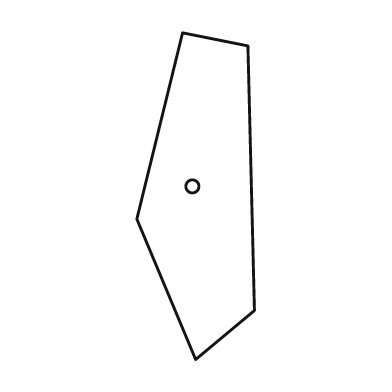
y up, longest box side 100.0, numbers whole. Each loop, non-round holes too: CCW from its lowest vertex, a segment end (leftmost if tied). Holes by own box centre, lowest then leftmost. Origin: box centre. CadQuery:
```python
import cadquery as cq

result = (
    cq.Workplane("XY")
    .moveTo(0.0, -50.0)
    .lineTo(18.0, -35.0)
    .lineTo(16.0, 46.0)
    .lineTo(-4.0, 50.0)
    .lineTo(-18.0, -7.0)
    .close()
    .moveTo(-1.0, 3.0)
    .circle(2.0)
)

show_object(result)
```